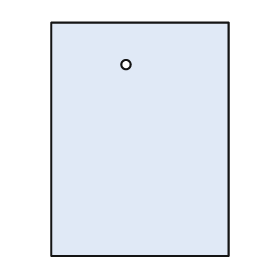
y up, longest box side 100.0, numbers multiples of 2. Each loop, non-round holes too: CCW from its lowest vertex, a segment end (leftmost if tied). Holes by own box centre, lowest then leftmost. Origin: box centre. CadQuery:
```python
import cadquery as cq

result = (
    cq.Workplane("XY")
    .moveTo(-38.0, -50.0)
    .lineTo(38.0, -50.0)
    .lineTo(38.0, 50.0)
    .lineTo(-38.0, 50.0)
    .close()
    .moveTo(-6.0, 32.0)
    .circle(2.0)
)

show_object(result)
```